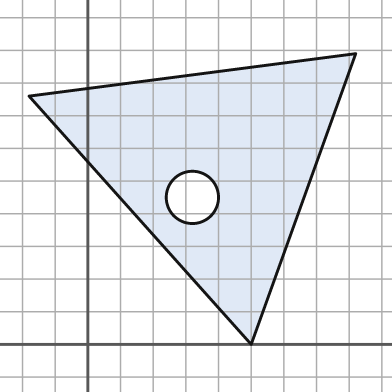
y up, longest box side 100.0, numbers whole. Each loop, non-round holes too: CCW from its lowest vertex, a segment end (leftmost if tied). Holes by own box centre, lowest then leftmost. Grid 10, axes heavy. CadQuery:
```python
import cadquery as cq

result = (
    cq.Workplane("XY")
    .moveTo(50.0, 0.0)
    .lineTo(82.0, 89.0)
    .lineTo(-18.0, 76.0)
    .close()
    .moveTo(32.0, 45.0)
    .circle(8.0)
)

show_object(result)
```